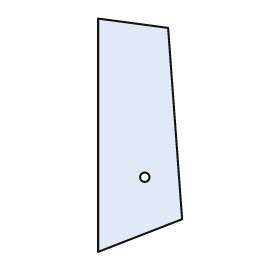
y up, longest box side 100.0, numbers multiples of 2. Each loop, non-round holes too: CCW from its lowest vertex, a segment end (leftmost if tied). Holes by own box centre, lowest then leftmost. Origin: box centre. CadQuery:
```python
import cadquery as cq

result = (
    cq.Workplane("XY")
    .moveTo(-18.0, -50.0)
    .lineTo(18.0, -36.0)
    .lineTo(12.0, 46.0)
    .lineTo(-18.0, 50.0)
    .close()
    .moveTo(2.0, -18.0)
    .circle(2.0)
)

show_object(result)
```